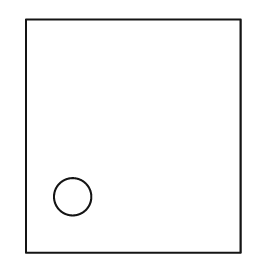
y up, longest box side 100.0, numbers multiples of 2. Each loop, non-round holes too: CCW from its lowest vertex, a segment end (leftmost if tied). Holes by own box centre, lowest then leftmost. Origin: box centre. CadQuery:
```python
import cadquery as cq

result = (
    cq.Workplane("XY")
    .moveTo(-46.0, -50.0)
    .lineTo(46.0, -50.0)
    .lineTo(46.0, 50.0)
    .lineTo(-46.0, 50.0)
    .close()
    .moveTo(-26.0, -26.0)
    .circle(8.0)
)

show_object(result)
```